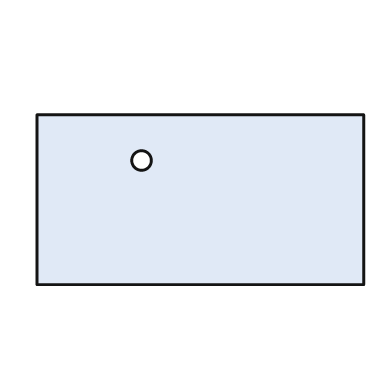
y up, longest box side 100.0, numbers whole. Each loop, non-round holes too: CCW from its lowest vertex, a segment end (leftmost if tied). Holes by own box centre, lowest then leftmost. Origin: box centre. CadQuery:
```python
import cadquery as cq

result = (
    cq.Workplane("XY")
    .moveTo(-50.0, -26.0)
    .lineTo(50.0, -26.0)
    .lineTo(50.0, 26.0)
    .lineTo(-50.0, 26.0)
    .close()
    .moveTo(-18.0, 12.0)
    .circle(3.0)
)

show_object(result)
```